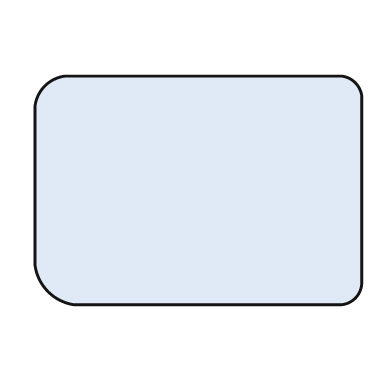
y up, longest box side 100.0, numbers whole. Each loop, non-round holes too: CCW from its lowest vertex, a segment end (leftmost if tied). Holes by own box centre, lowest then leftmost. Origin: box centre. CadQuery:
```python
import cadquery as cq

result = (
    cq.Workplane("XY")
    .moveTo(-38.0, -35.0)
    .lineTo(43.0, -35.0)
    .threePointArc((48.0, -33.0), (50.0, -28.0))
    .lineTo(50.0, 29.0)
    .threePointArc((48.0, 33.0), (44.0, 35.0))
    .lineTo(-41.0, 35.0)
    .threePointArc((-47.0, 32.0), (-50.0, 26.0))
    .lineTo(-50.0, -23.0)
    .threePointArc((-46.0, -31.0), (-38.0, -35.0))
    .close()
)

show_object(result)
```